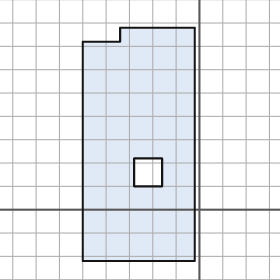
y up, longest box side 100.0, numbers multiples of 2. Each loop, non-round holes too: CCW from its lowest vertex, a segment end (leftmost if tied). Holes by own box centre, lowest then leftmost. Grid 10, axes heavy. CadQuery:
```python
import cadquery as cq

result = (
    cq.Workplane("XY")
    .moveTo(-50.0, -22.0)
    .lineTo(-2.0, -22.0)
    .lineTo(-2.0, 78.0)
    .lineTo(-34.0, 78.0)
    .lineTo(-34.0, 72.0)
    .lineTo(-50.0, 72.0)
    .close()
    .moveTo(-28.0, 10.0)
    .lineTo(-16.0, 10.0)
    .lineTo(-16.0, 22.0)
    .lineTo(-28.0, 22.0)
    .close()
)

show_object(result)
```